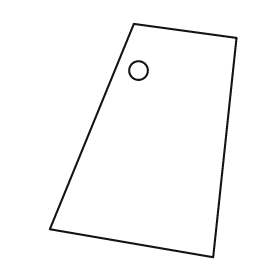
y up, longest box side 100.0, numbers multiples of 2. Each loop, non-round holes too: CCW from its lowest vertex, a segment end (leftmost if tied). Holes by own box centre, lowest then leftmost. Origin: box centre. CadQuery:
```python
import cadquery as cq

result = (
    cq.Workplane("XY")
    .moveTo(30.0, -50.0)
    .lineTo(40.0, 44.0)
    .lineTo(-4.0, 50.0)
    .lineTo(-40.0, -38.0)
    .close()
    .moveTo(-2.0, 30.0)
    .circle(4.0)
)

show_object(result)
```